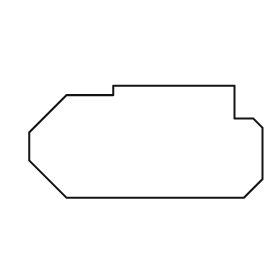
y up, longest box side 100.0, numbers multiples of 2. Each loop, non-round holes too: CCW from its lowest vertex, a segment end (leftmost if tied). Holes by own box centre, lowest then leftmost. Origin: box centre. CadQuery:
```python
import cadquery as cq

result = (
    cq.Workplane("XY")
    .moveTo(-34.0, -24.0)
    .lineTo(42.0, -24.0)
    .lineTo(50.0, -16.0)
    .lineTo(50.0, 6.0)
    .lineTo(46.0, 10.0)
    .lineTo(38.0, 10.0)
    .lineTo(38.0, 24.0)
    .lineTo(-14.0, 24.0)
    .lineTo(-14.0, 20.0)
    .lineTo(-34.0, 20.0)
    .lineTo(-50.0, 4.0)
    .lineTo(-50.0, -8.0)
    .close()
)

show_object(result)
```